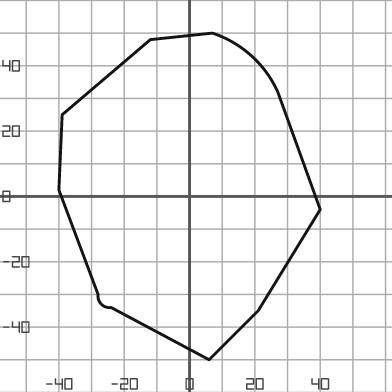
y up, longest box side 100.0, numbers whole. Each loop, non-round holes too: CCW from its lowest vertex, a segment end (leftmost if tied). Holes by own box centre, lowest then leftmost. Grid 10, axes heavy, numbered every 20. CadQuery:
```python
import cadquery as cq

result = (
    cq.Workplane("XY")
    .moveTo(6.0, -50.0)
    .lineTo(21.0, -35.0)
    .lineTo(40.0, -4.0)
    .lineTo(27.0, 32.0)
    .threePointArc((19.0, 43.0), (7.0, 50.0))
    .lineTo(-12.0, 48.0)
    .lineTo(-39.0, 25.0)
    .lineTo(-40.0, 2.0)
    .lineTo(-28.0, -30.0)
    .threePointArc((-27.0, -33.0), (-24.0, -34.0))
    .close()
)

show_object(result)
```